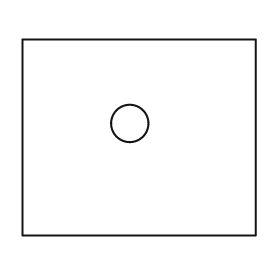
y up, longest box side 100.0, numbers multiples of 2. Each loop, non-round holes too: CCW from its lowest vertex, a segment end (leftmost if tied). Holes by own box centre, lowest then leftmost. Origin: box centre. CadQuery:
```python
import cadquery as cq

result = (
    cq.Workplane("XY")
    .moveTo(-50.0, -42.0)
    .lineTo(50.0, -42.0)
    .lineTo(50.0, 42.0)
    .lineTo(-50.0, 42.0)
    .close()
    .moveTo(-4.0, 6.0)
    .circle(8.0)
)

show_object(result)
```